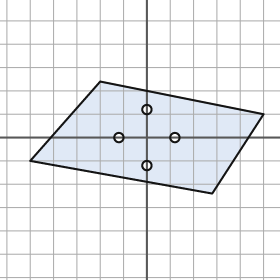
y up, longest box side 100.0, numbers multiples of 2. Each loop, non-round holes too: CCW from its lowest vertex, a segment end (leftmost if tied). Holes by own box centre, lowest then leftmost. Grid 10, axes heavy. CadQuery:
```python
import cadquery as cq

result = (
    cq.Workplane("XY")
    .moveTo(28.0, -24.0)
    .lineTo(50.0, 10.0)
    .lineTo(-20.0, 24.0)
    .lineTo(-50.0, -10.0)
    .close()
    .moveTo(0.0, -12.0)
    .circle(2.0)
    .moveTo(-12.0, 0.0)
    .circle(2.0)
    .moveTo(12.0, 0.0)
    .circle(2.0)
    .moveTo(0.0, 12.0)
    .circle(2.0)
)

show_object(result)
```